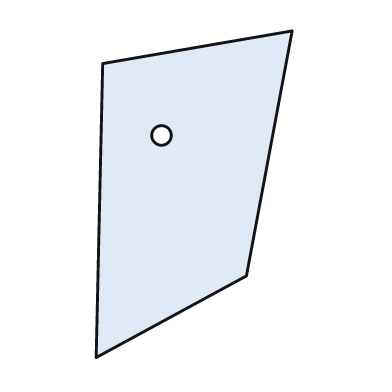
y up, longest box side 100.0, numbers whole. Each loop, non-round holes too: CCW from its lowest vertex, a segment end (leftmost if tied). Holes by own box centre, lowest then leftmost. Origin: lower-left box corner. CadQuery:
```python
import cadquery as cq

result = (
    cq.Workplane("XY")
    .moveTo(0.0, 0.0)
    .lineTo(46.0, 25.0)
    .lineTo(60.0, 100.0)
    .lineTo(2.0, 90.0)
    .close()
    .moveTo(20.0, 68.0)
    .circle(3.0)
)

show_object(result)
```